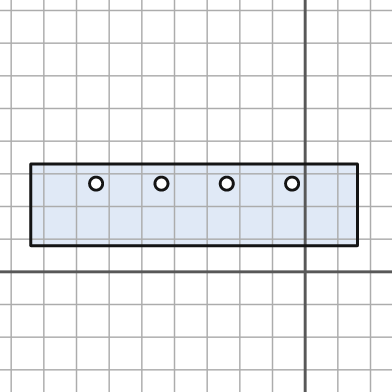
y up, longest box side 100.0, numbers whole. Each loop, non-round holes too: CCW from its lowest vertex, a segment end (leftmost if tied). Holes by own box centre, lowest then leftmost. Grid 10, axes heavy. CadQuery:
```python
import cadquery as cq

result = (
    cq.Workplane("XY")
    .moveTo(-84.0, 8.0)
    .lineTo(16.0, 8.0)
    .lineTo(16.0, 33.0)
    .lineTo(-84.0, 33.0)
    .close()
    .moveTo(-64.0, 27.0)
    .circle(2.0)
    .moveTo(-44.0, 27.0)
    .circle(2.0)
    .moveTo(-24.0, 27.0)
    .circle(2.0)
    .moveTo(-4.0, 27.0)
    .circle(2.0)
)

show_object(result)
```